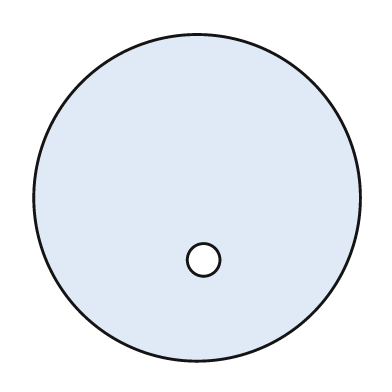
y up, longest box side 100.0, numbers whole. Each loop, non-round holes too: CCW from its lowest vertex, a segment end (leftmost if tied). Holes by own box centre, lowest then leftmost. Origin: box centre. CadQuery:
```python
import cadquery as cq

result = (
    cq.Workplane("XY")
    .moveTo(0.0, 0.0)
    .circle(50.0)
    .moveTo(2.0, -19.0)
    .circle(5.0)
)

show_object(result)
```